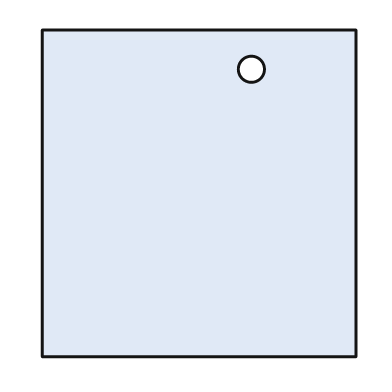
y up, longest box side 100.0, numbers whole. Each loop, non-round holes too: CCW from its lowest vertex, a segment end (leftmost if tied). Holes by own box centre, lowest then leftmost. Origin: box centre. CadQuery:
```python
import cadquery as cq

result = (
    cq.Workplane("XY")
    .moveTo(-48.0, -50.0)
    .lineTo(48.0, -50.0)
    .lineTo(48.0, 50.0)
    .lineTo(-48.0, 50.0)
    .close()
    .moveTo(16.0, 38.0)
    .circle(4.0)
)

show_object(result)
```